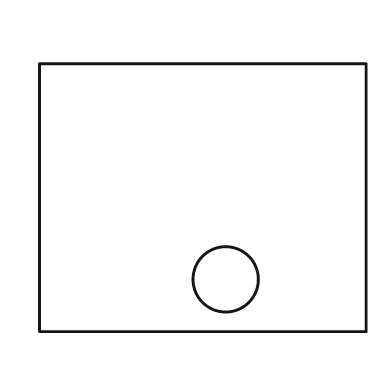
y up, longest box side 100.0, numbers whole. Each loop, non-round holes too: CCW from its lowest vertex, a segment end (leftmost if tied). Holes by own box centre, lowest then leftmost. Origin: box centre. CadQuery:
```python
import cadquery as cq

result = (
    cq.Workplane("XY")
    .moveTo(-50.0, -41.0)
    .lineTo(50.0, -41.0)
    .lineTo(50.0, 41.0)
    .lineTo(-50.0, 41.0)
    .close()
    .moveTo(7.0, -25.0)
    .circle(10.0)
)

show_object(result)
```